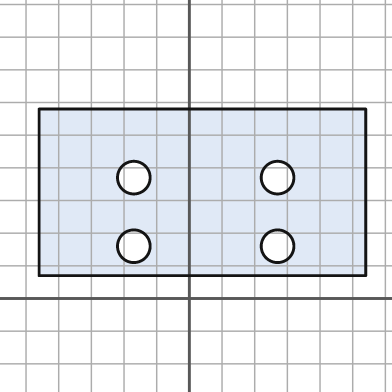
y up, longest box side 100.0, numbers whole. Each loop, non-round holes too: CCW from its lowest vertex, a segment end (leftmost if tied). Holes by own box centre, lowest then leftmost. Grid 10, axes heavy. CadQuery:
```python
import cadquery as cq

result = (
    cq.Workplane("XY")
    .moveTo(-46.0, 7.0)
    .lineTo(54.0, 7.0)
    .lineTo(54.0, 58.0)
    .lineTo(-46.0, 58.0)
    .close()
    .moveTo(-17.0, 16.0)
    .circle(5.0)
    .moveTo(27.0, 16.0)
    .circle(5.0)
    .moveTo(-17.0, 37.0)
    .circle(5.0)
    .moveTo(27.0, 37.0)
    .circle(5.0)
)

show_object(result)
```